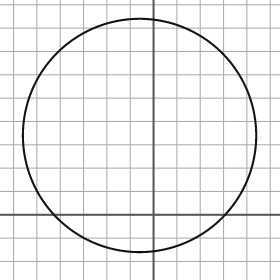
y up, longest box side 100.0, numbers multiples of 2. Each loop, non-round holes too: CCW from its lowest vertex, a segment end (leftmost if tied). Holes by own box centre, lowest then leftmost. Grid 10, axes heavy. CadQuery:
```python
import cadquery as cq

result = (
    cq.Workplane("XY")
    .moveTo(-6.0, 34.0)
    .circle(50.0)
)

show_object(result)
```